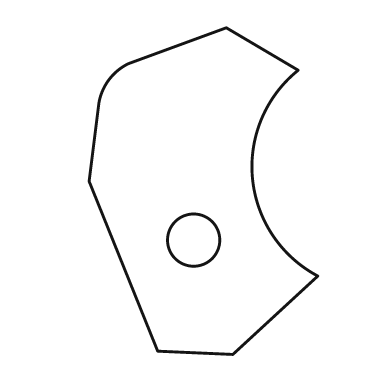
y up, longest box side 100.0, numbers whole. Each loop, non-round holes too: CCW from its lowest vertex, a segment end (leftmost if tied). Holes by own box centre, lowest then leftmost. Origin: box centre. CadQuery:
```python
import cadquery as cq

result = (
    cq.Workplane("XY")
    .moveTo(9.0, -50.0)
    .lineTo(35.0, -26.0)
    .threePointArc((15.0, 4.0), (29.0, 37.0))
    .lineTo(7.0, 50.0)
    .lineTo(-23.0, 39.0)
    .threePointArc((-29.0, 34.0), (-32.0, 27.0))
    .lineTo(-35.0, 3.0)
    .lineTo(-14.0, -49.0)
    .close()
    .moveTo(-3.0, -15.0)
    .circle(8.0)
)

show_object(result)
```